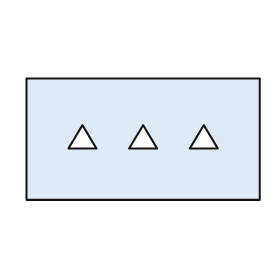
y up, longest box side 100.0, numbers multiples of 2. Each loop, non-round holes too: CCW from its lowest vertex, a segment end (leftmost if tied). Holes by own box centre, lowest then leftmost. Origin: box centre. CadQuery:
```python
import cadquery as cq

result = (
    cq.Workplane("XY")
    .moveTo(-50.0, -26.0)
    .lineTo(50.0, -26.0)
    .lineTo(50.0, 26.0)
    .lineTo(-50.0, 26.0)
    .close()
    .moveTo(-32.0, -4.0)
    .lineTo(-20.0, -4.0)
    .lineTo(-26.0, 6.0)
    .close()
    .moveTo(-6.0, -4.0)
    .lineTo(6.0, -4.0)
    .lineTo(0.0, 6.0)
    .close()
    .moveTo(20.0, -4.0)
    .lineTo(32.0, -4.0)
    .lineTo(26.0, 6.0)
    .close()
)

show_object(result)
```